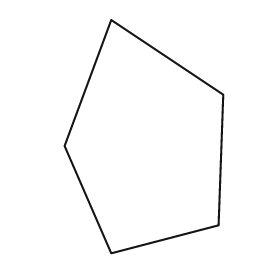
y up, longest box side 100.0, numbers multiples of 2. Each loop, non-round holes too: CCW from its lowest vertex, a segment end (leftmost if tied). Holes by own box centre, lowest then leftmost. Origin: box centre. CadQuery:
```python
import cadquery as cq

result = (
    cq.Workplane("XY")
    .moveTo(-14.0, -50.0)
    .lineTo(32.0, -38.0)
    .lineTo(34.0, 18.0)
    .lineTo(-14.0, 50.0)
    .lineTo(-34.0, -4.0)
    .close()
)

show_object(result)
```